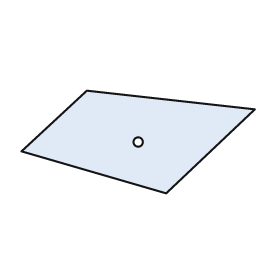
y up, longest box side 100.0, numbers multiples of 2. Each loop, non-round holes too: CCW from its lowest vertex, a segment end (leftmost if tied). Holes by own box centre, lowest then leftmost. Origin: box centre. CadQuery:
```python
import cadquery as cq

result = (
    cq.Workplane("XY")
    .moveTo(12.0, -22.0)
    .lineTo(50.0, 14.0)
    .lineTo(-22.0, 22.0)
    .lineTo(-50.0, -4.0)
    .close()
    .moveTo(0.0, 0.0)
    .circle(2.0)
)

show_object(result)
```